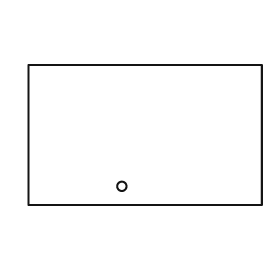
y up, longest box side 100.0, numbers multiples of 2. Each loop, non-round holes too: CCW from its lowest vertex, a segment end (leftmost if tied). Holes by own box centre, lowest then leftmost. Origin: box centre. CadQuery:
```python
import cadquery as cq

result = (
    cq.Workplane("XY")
    .moveTo(-50.0, -30.0)
    .lineTo(50.0, -30.0)
    .lineTo(50.0, 30.0)
    .lineTo(-50.0, 30.0)
    .close()
    .moveTo(-10.0, -22.0)
    .circle(2.0)
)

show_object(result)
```